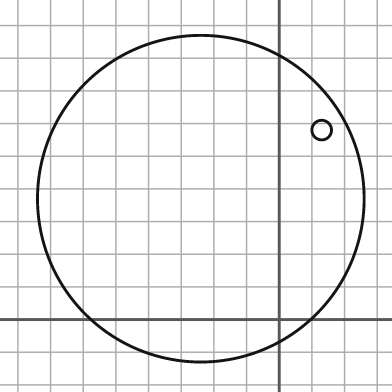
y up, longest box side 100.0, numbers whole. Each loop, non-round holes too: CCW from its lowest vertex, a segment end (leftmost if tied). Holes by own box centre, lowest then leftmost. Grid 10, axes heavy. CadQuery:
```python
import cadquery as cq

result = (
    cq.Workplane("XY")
    .moveTo(-24.0, 37.0)
    .circle(50.0)
    .moveTo(13.0, 58.0)
    .circle(3.0)
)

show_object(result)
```